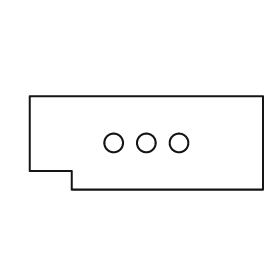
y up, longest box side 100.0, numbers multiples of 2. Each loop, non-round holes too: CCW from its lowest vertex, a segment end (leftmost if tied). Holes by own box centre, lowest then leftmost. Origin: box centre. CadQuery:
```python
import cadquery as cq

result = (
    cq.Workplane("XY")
    .moveTo(-32.0, -20.0)
    .lineTo(50.0, -20.0)
    .lineTo(50.0, 20.0)
    .lineTo(-50.0, 20.0)
    .lineTo(-50.0, -12.0)
    .lineTo(-32.0, -12.0)
    .close()
    .moveTo(-14.0, 0.0)
    .circle(4.0)
    .moveTo(0.0, 0.0)
    .circle(4.0)
    .moveTo(14.0, 0.0)
    .circle(4.0)
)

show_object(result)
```